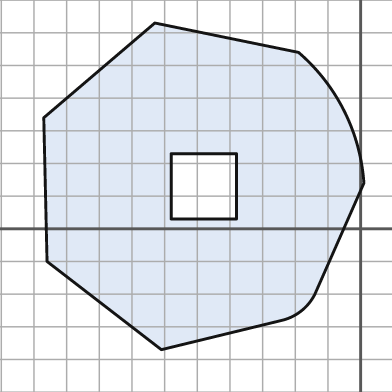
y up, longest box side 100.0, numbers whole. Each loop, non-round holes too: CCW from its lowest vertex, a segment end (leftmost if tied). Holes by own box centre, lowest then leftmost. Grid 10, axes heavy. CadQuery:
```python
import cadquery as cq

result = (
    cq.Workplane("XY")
    .moveTo(-61.0, -37.0)
    .lineTo(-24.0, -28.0)
    .threePointArc((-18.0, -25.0), (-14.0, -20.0))
    .lineTo(1.0, 14.0)
    .threePointArc((-5.0, 36.0), (-19.0, 54.0))
    .lineTo(-63.0, 63.0)
    .lineTo(-97.0, 34.0)
    .lineTo(-96.0, -10.0)
    .close()
    .moveTo(-58.0, 3.0)
    .lineTo(-38.0, 3.0)
    .lineTo(-38.0, 23.0)
    .lineTo(-58.0, 23.0)
    .close()
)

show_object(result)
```